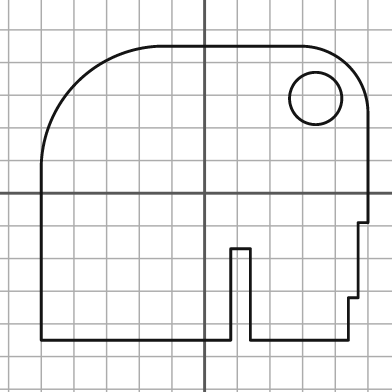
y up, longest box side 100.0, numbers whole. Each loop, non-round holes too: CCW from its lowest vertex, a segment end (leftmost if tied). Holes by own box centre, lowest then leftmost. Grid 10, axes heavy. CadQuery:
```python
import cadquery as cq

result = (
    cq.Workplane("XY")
    .moveTo(-50.0, -45.0)
    .lineTo(8.0, -45.0)
    .lineTo(8.0, -17.0)
    .lineTo(14.0, -17.0)
    .lineTo(14.0, -45.0)
    .lineTo(44.0, -45.0)
    .lineTo(44.0, -32.0)
    .lineTo(47.0, -32.0)
    .lineTo(47.0, -9.0)
    .lineTo(50.0, -9.0)
    .lineTo(50.0, 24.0)
    .threePointArc((44.0, 39.0), (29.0, 45.0))
    .lineTo(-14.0, 45.0)
    .threePointArc((-39.0, 34.0), (-50.0, 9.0))
    .close()
    .moveTo(34.0, 29.0)
    .circle(8.0)
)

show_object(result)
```